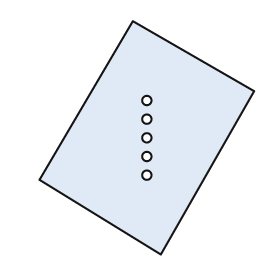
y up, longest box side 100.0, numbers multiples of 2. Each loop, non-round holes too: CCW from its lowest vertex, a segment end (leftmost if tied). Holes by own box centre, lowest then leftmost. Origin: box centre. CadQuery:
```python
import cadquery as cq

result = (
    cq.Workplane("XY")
    .moveTo(6.0, -50.0)
    .lineTo(46.0, 20.0)
    .lineTo(-6.0, 50.0)
    .lineTo(-46.0, -18.0)
    .close()
    .moveTo(0.0, -16.0)
    .circle(2.0)
    .moveTo(0.0, -8.0)
    .circle(2.0)
    .moveTo(0.0, 0.0)
    .circle(2.0)
    .moveTo(0.0, 8.0)
    .circle(2.0)
    .moveTo(0.0, 16.0)
    .circle(2.0)
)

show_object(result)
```